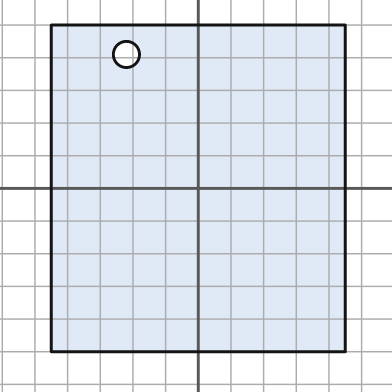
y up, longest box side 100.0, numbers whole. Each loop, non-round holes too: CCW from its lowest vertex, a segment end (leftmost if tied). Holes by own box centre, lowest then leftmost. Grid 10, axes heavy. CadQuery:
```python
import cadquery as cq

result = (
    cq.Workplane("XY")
    .moveTo(-45.0, -50.0)
    .lineTo(45.0, -50.0)
    .lineTo(45.0, 50.0)
    .lineTo(-45.0, 50.0)
    .close()
    .moveTo(-22.0, 41.0)
    .circle(4.0)
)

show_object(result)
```